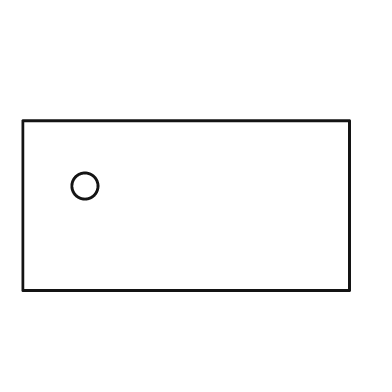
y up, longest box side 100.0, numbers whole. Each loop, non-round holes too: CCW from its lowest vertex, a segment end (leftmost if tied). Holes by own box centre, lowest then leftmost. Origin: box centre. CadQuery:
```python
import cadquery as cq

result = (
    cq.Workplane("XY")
    .moveTo(-50.0, -26.0)
    .lineTo(50.0, -26.0)
    .lineTo(50.0, 26.0)
    .lineTo(-50.0, 26.0)
    .close()
    .moveTo(-31.0, 6.0)
    .circle(4.0)
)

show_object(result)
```